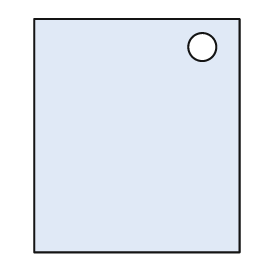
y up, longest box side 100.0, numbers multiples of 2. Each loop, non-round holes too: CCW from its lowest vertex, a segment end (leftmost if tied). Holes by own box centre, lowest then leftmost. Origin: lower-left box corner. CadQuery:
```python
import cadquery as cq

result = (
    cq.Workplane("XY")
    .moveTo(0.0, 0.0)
    .lineTo(88.0, 0.0)
    .lineTo(88.0, 100.0)
    .lineTo(0.0, 100.0)
    .close()
    .moveTo(72.0, 88.0)
    .circle(6.0)
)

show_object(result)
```